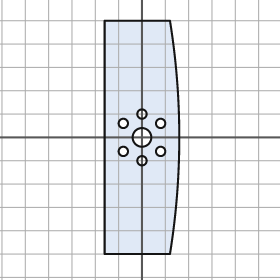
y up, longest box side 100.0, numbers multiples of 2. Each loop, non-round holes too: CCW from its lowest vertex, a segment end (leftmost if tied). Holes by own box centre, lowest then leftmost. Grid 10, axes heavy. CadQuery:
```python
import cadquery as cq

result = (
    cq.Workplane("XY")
    .moveTo(-16.0, -50.0)
    .lineTo(12.0, -50.0)
    .threePointArc((16.0, 0.0), (12.0, 50.0))
    .lineTo(-16.0, 50.0)
    .close()
    .moveTo(0.0, -10.0)
    .circle(2.0)
    .moveTo(-8.0, -6.0)
    .circle(2.0)
    .moveTo(8.0, -6.0)
    .circle(2.0)
    .moveTo(0.0, 0.0)
    .circle(4.0)
    .moveTo(-8.0, 6.0)
    .circle(2.0)
    .moveTo(8.0, 6.0)
    .circle(2.0)
    .moveTo(0.0, 10.0)
    .circle(2.0)
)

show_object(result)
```